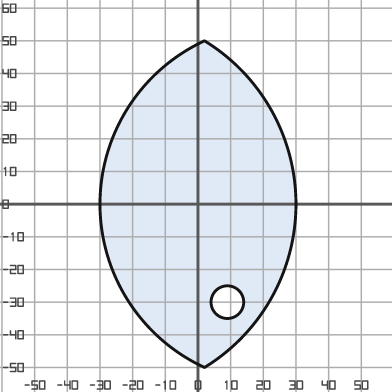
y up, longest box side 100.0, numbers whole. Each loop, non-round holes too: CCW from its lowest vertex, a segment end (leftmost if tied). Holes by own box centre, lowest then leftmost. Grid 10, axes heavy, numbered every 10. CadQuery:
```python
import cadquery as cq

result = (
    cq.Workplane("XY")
    .moveTo(2.0, -50.0)
    .threePointArc((30.0, 0.0), (2.0, 50.0))
    .threePointArc((-30.0, 0.0), (2.0, -50.0))
    .close()
    .moveTo(9.0, -30.0)
    .circle(5.0)
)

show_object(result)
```